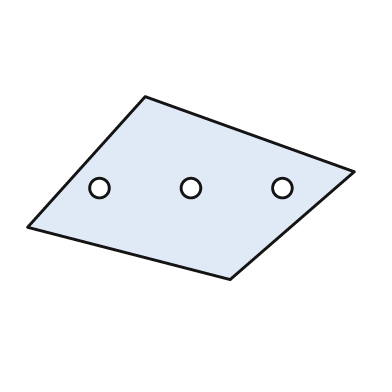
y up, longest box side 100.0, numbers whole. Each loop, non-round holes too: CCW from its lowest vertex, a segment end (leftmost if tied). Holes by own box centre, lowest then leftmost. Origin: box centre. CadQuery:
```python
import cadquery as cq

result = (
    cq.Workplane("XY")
    .moveTo(12.0, -28.0)
    .lineTo(50.0, 5.0)
    .lineTo(-14.0, 28.0)
    .lineTo(-50.0, -12.0)
    .close()
    .moveTo(-28.0, 0.0)
    .circle(3.0)
    .moveTo(0.0, 0.0)
    .circle(3.0)
    .moveTo(28.0, 0.0)
    .circle(3.0)
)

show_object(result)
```